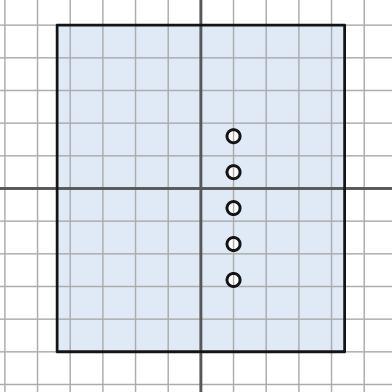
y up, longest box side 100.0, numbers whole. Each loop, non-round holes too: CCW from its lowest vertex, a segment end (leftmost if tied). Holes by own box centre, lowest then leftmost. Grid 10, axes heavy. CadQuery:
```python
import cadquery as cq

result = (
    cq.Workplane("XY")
    .moveTo(-44.0, -50.0)
    .lineTo(44.0, -50.0)
    .lineTo(44.0, 50.0)
    .lineTo(-44.0, 50.0)
    .close()
    .moveTo(10.0, -28.0)
    .circle(2.0)
    .moveTo(10.0, -17.0)
    .circle(2.0)
    .moveTo(10.0, -6.0)
    .circle(2.0)
    .moveTo(10.0, 5.0)
    .circle(2.0)
    .moveTo(10.0, 16.0)
    .circle(2.0)
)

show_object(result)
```